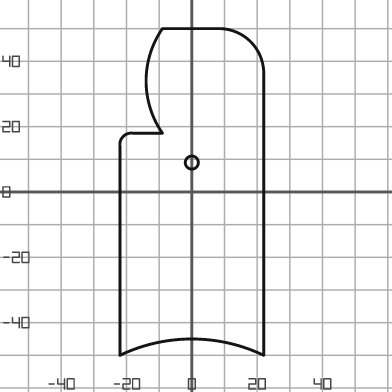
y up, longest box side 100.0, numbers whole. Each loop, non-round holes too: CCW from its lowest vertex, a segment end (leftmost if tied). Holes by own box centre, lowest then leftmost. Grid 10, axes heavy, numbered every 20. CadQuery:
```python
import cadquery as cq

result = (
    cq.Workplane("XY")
    .moveTo(-22.0, -50.0)
    .threePointArc((0.0, -45.0), (22.0, -50.0))
    .lineTo(22.0, 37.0)
    .threePointArc((18.0, 46.0), (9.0, 50.0))
    .lineTo(-9.0, 50.0)
    .threePointArc((-14.0, 34.0), (-9.0, 18.0))
    .lineTo(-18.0, 18.0)
    .threePointArc((-21.0, 17.0), (-22.0, 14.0))
    .close()
    .moveTo(0.0, 9.0)
    .circle(2.0)
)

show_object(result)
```